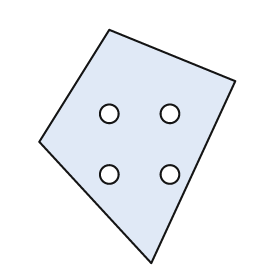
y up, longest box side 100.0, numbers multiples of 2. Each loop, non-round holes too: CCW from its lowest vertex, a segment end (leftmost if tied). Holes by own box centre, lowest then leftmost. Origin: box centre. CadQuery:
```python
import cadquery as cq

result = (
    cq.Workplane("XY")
    .moveTo(6.0, -50.0)
    .lineTo(42.0, 28.0)
    .lineTo(-12.0, 50.0)
    .lineTo(-42.0, 2.0)
    .close()
    .moveTo(-12.0, -12.0)
    .circle(4.0)
    .moveTo(14.0, -12.0)
    .circle(4.0)
    .moveTo(-12.0, 14.0)
    .circle(4.0)
    .moveTo(14.0, 14.0)
    .circle(4.0)
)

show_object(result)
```